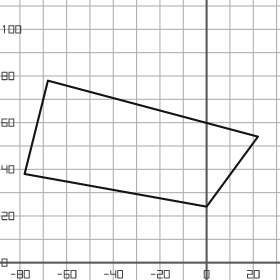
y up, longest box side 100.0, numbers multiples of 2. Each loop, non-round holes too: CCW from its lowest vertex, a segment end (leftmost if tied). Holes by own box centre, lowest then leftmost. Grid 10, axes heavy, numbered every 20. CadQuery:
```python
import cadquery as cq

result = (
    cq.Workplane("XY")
    .moveTo(0.0, 24.0)
    .lineTo(22.0, 54.0)
    .lineTo(-68.0, 78.0)
    .lineTo(-78.0, 38.0)
    .close()
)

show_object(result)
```